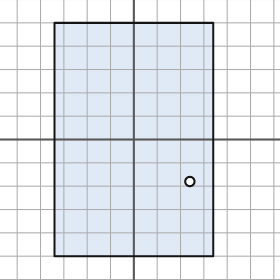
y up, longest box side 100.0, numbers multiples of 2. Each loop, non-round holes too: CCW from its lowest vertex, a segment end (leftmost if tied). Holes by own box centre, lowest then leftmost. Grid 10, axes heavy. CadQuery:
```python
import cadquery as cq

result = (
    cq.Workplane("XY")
    .moveTo(-34.0, -50.0)
    .lineTo(34.0, -50.0)
    .lineTo(34.0, 50.0)
    .lineTo(-34.0, 50.0)
    .close()
    .moveTo(24.0, -18.0)
    .circle(2.0)
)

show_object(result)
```